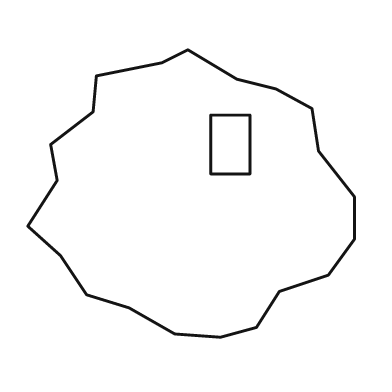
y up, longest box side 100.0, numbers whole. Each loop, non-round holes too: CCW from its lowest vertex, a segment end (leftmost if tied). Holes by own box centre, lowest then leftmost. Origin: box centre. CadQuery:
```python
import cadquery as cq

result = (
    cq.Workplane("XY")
    .moveTo(9.0, -44.0)
    .lineTo(20.0, -41.0)
    .lineTo(27.0, -30.0)
    .lineTo(42.0, -25.0)
    .lineTo(50.0, -14.0)
    .lineTo(50.0, -1.0)
    .lineTo(39.0, 13.0)
    .lineTo(37.0, 26.0)
    .lineTo(26.0, 32.0)
    .lineTo(14.0, 35.0)
    .lineTo(-1.0, 44.0)
    .lineTo(-9.0, 40.0)
    .lineTo(-29.0, 36.0)
    .lineTo(-30.0, 25.0)
    .lineTo(-43.0, 15.0)
    .lineTo(-41.0, 4.0)
    .lineTo(-50.0, -10.0)
    .lineTo(-40.0, -19.0)
    .lineTo(-32.0, -31.0)
    .lineTo(-19.0, -35.0)
    .lineTo(-5.0, -43.0)
    .close()
    .moveTo(6.0, 6.0)
    .lineTo(18.0, 6.0)
    .lineTo(18.0, 24.0)
    .lineTo(6.0, 24.0)
    .close()
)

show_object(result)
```